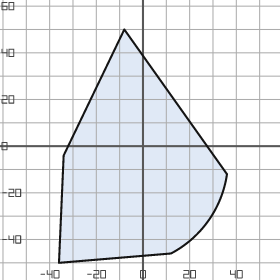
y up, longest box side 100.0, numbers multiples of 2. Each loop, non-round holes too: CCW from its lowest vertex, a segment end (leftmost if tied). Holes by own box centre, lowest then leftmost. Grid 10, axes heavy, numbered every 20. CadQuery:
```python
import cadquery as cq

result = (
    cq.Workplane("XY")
    .moveTo(-36.0, -50.0)
    .lineTo(12.0, -46.0)
    .threePointArc((28.0, -32.0), (36.0, -12.0))
    .lineTo(-8.0, 50.0)
    .lineTo(-34.0, -4.0)
    .close()
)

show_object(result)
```